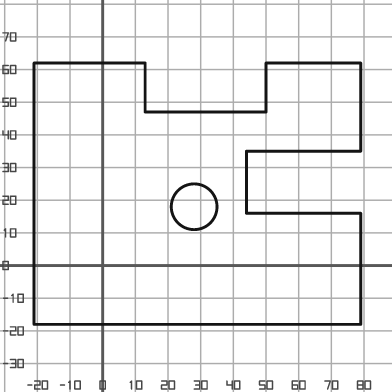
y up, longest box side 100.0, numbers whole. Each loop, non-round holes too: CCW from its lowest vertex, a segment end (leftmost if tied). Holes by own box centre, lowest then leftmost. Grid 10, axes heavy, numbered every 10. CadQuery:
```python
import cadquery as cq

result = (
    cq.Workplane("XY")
    .moveTo(-21.0, -18.0)
    .lineTo(79.0, -18.0)
    .lineTo(79.0, 16.0)
    .lineTo(44.0, 16.0)
    .lineTo(44.0, 35.0)
    .lineTo(79.0, 35.0)
    .lineTo(79.0, 62.0)
    .lineTo(50.0, 62.0)
    .lineTo(50.0, 47.0)
    .lineTo(13.0, 47.0)
    .lineTo(13.0, 62.0)
    .lineTo(-21.0, 62.0)
    .close()
    .moveTo(28.0, 18.0)
    .circle(7.0)
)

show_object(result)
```